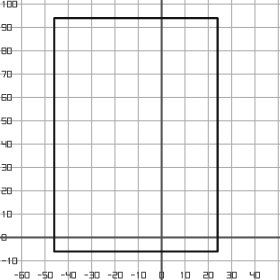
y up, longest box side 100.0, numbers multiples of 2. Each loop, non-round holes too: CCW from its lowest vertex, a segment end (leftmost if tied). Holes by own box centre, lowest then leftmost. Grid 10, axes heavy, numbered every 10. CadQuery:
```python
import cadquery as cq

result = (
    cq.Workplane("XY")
    .moveTo(-46.0, -6.0)
    .lineTo(24.0, -6.0)
    .lineTo(24.0, 94.0)
    .lineTo(-46.0, 94.0)
    .close()
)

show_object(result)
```